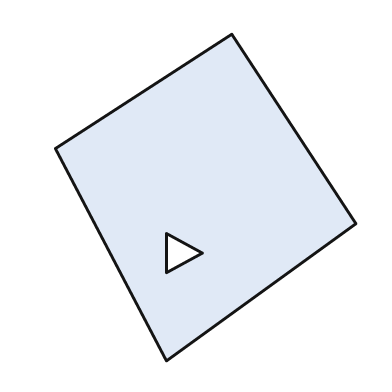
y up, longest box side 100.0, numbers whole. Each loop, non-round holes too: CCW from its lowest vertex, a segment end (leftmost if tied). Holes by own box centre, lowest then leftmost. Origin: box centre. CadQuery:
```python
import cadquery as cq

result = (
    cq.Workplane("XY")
    .moveTo(-12.0, -50.0)
    .lineTo(46.0, -8.0)
    .lineTo(8.0, 50.0)
    .lineTo(-46.0, 15.0)
    .close()
    .moveTo(-12.0, -23.0)
    .lineTo(-1.0, -17.0)
    .lineTo(-12.0, -11.0)
    .close()
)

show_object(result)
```